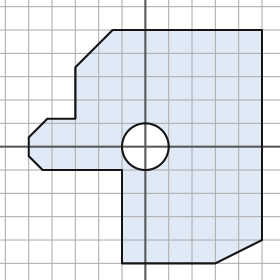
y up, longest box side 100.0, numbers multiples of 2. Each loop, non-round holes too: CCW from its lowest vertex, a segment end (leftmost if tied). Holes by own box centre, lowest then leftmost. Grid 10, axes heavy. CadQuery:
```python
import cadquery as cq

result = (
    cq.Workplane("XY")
    .moveTo(-10.0, -50.0)
    .lineTo(30.0, -50.0)
    .lineTo(50.0, -40.0)
    .lineTo(50.0, 50.0)
    .lineTo(-14.0, 50.0)
    .lineTo(-30.0, 34.0)
    .lineTo(-30.0, 12.0)
    .lineTo(-42.0, 12.0)
    .lineTo(-50.0, 4.0)
    .lineTo(-50.0, -4.0)
    .lineTo(-44.0, -10.0)
    .lineTo(-10.0, -10.0)
    .close()
    .moveTo(0.0, 0.0)
    .circle(10.0)
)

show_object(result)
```